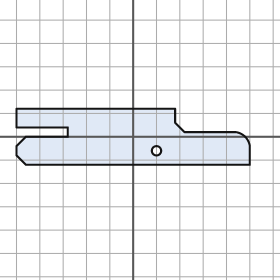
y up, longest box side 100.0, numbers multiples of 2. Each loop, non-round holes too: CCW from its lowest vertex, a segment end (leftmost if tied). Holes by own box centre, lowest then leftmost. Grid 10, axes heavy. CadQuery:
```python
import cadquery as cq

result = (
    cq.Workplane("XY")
    .moveTo(-46.0, -12.0)
    .lineTo(50.0, -12.0)
    .lineTo(50.0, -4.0)
    .threePointArc((48.0, 0.0), (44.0, 2.0))
    .lineTo(22.0, 2.0)
    .lineTo(18.0, 6.0)
    .lineTo(18.0, 12.0)
    .lineTo(-50.0, 12.0)
    .lineTo(-50.0, 4.0)
    .lineTo(-28.0, 4.0)
    .lineTo(-28.0, 0.0)
    .lineTo(-46.0, 0.0)
    .lineTo(-50.0, -4.0)
    .lineTo(-50.0, -8.0)
    .close()
    .moveTo(10.0, -6.0)
    .circle(2.0)
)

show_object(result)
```